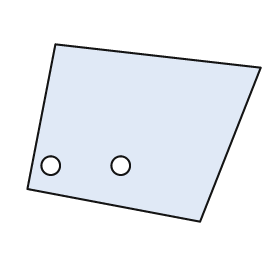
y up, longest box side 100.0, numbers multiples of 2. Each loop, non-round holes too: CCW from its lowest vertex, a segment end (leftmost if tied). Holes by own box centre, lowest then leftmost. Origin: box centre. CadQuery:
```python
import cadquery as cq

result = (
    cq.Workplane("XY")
    .moveTo(24.0, -38.0)
    .lineTo(50.0, 28.0)
    .lineTo(-38.0, 38.0)
    .lineTo(-50.0, -24.0)
    .close()
    .moveTo(-40.0, -14.0)
    .circle(4.0)
    .moveTo(-10.0, -14.0)
    .circle(4.0)
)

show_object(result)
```